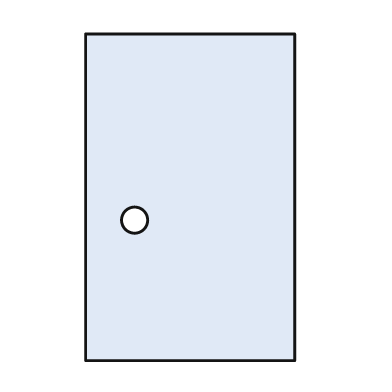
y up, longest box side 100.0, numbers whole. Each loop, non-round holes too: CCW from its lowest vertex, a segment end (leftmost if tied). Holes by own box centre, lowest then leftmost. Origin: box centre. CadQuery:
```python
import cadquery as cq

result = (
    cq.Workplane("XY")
    .moveTo(-32.0, -50.0)
    .lineTo(32.0, -50.0)
    .lineTo(32.0, 50.0)
    .lineTo(-32.0, 50.0)
    .close()
    .moveTo(-17.0, -7.0)
    .circle(4.0)
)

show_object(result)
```